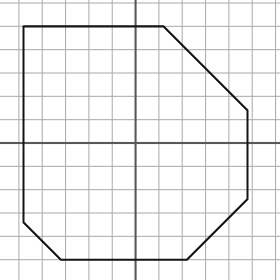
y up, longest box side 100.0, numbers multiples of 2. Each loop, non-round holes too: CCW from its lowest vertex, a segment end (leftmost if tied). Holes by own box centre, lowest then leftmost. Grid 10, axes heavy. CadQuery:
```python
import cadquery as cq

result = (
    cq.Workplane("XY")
    .moveTo(-32.0, -50.0)
    .lineTo(22.0, -50.0)
    .lineTo(48.0, -24.0)
    .lineTo(48.0, 14.0)
    .lineTo(12.0, 50.0)
    .lineTo(-48.0, 50.0)
    .lineTo(-48.0, -34.0)
    .close()
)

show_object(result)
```